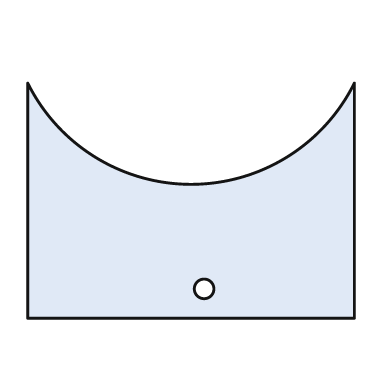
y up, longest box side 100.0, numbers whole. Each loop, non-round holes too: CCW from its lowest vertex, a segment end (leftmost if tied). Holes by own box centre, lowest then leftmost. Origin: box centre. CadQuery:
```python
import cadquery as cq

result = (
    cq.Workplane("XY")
    .moveTo(-50.0, -36.0)
    .lineTo(50.0, -36.0)
    .lineTo(50.0, 36.0)
    .threePointArc((0.0, 5.0), (-50.0, 36.0))
    .close()
    .moveTo(4.0, -27.0)
    .circle(3.0)
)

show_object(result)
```